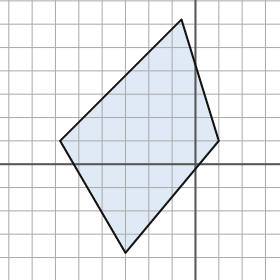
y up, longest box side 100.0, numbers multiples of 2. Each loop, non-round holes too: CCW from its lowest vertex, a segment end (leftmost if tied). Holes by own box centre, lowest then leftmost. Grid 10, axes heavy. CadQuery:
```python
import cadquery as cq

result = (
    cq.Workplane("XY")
    .moveTo(-30.0, -38.0)
    .lineTo(10.0, 10.0)
    .lineTo(-6.0, 62.0)
    .lineTo(-58.0, 10.0)
    .close()
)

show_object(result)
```